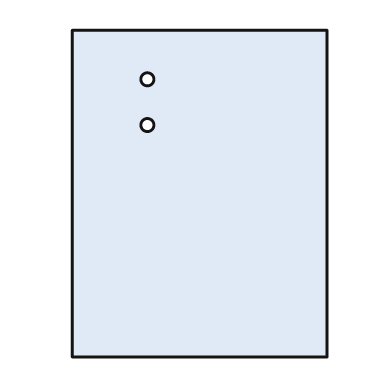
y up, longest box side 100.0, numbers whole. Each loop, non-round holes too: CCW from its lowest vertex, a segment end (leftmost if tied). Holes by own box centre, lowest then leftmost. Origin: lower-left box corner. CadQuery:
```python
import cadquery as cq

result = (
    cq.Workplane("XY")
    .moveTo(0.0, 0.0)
    .lineTo(78.0, 0.0)
    .lineTo(78.0, 100.0)
    .lineTo(0.0, 100.0)
    .close()
    .moveTo(23.0, 71.0)
    .circle(2.0)
    .moveTo(23.0, 85.0)
    .circle(2.0)
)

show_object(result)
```